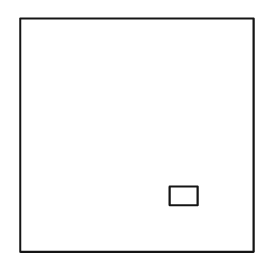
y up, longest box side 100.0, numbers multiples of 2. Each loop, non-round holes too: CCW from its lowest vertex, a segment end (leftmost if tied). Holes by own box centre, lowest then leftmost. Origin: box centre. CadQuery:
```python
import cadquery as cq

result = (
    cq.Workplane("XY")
    .moveTo(-50.0, -50.0)
    .lineTo(50.0, -50.0)
    .lineTo(50.0, 50.0)
    .lineTo(-50.0, 50.0)
    .close()
    .moveTo(14.0, -30.0)
    .lineTo(26.0, -30.0)
    .lineTo(26.0, -22.0)
    .lineTo(14.0, -22.0)
    .close()
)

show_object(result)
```